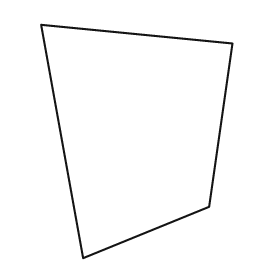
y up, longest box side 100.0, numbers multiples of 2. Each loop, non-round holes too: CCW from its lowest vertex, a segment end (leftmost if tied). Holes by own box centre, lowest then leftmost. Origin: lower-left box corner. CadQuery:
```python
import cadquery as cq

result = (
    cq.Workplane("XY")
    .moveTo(18.0, 0.0)
    .lineTo(72.0, 22.0)
    .lineTo(82.0, 92.0)
    .lineTo(0.0, 100.0)
    .close()
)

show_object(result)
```